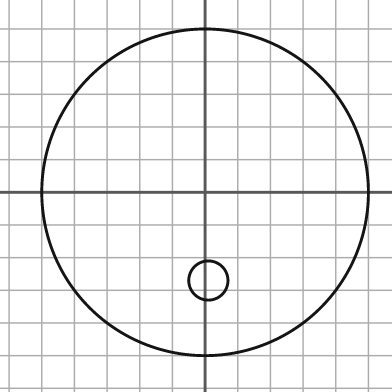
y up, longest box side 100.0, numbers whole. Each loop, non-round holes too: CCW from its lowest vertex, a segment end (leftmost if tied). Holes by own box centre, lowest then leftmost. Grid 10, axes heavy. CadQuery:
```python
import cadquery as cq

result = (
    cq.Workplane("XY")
    .moveTo(0.0, 0.0)
    .circle(50.0)
    .moveTo(1.0, -27.0)
    .circle(6.0)
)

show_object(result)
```